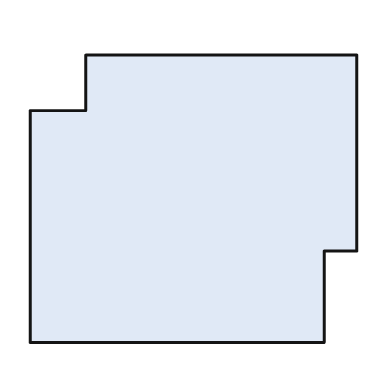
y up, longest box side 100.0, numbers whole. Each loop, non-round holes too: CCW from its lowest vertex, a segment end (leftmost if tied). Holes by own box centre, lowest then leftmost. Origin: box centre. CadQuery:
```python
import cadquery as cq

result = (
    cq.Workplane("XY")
    .moveTo(-50.0, -44.0)
    .lineTo(40.0, -44.0)
    .lineTo(40.0, -16.0)
    .lineTo(50.0, -16.0)
    .lineTo(50.0, 44.0)
    .lineTo(-33.0, 44.0)
    .lineTo(-33.0, 27.0)
    .lineTo(-50.0, 27.0)
    .close()
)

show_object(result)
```